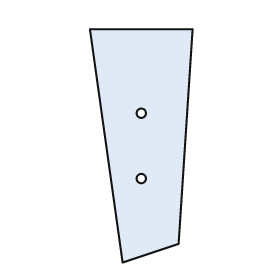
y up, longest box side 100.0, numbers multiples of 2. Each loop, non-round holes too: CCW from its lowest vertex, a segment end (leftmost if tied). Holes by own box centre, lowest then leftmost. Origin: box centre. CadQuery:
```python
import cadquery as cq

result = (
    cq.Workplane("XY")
    .moveTo(-8.0, -50.0)
    .lineTo(16.0, -42.0)
    .lineTo(22.0, 50.0)
    .lineTo(-22.0, 50.0)
    .close()
    .moveTo(0.0, -14.0)
    .circle(2.0)
    .moveTo(0.0, 14.0)
    .circle(2.0)
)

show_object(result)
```